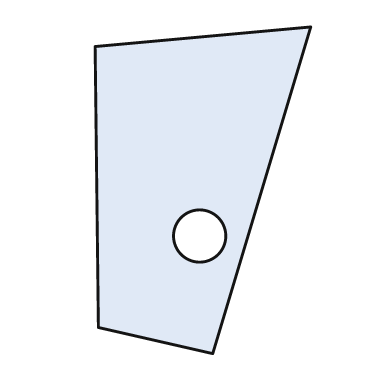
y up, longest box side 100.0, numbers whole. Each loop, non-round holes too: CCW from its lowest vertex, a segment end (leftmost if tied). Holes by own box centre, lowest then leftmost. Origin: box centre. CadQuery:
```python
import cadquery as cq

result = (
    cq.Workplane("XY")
    .moveTo(3.0, -50.0)
    .lineTo(33.0, 50.0)
    .lineTo(-33.0, 44.0)
    .lineTo(-32.0, -42.0)
    .close()
    .moveTo(-1.0, -14.0)
    .circle(8.0)
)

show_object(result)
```